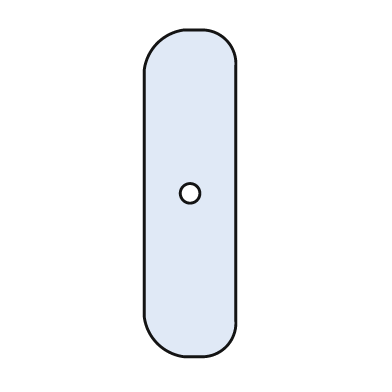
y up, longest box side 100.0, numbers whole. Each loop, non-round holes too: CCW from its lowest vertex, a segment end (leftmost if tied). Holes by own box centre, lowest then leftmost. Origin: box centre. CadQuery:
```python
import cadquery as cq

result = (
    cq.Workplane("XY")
    .moveTo(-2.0, -50.0)
    .lineTo(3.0, -50.0)
    .threePointArc((11.0, -47.0), (14.0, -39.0))
    .lineTo(14.0, 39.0)
    .threePointArc((11.0, 47.0), (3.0, 50.0))
    .lineTo(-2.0, 50.0)
    .threePointArc((-10.0, 46.0), (-14.0, 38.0))
    .lineTo(-14.0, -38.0)
    .threePointArc((-10.0, -46.0), (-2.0, -50.0))
    .close()
    .moveTo(0.0, 0.0)
    .circle(3.0)
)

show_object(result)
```